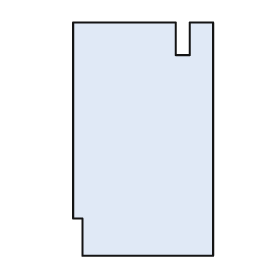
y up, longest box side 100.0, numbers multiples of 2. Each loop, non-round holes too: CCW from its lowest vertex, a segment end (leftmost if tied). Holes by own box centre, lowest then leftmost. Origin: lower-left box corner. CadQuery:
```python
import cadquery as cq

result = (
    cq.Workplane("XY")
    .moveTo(4.0, 0.0)
    .lineTo(60.0, 0.0)
    .lineTo(60.0, 100.0)
    .lineTo(50.0, 100.0)
    .lineTo(50.0, 86.0)
    .lineTo(44.0, 86.0)
    .lineTo(44.0, 100.0)
    .lineTo(0.0, 100.0)
    .lineTo(0.0, 16.0)
    .lineTo(4.0, 16.0)
    .close()
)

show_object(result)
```